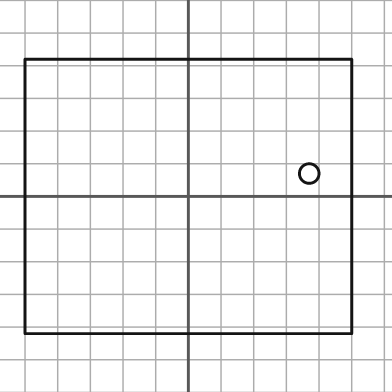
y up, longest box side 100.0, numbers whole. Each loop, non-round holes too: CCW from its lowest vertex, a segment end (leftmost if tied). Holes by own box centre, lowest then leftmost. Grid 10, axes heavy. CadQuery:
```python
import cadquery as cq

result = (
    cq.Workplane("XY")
    .moveTo(-50.0, -42.0)
    .lineTo(50.0, -42.0)
    .lineTo(50.0, 42.0)
    .lineTo(-50.0, 42.0)
    .close()
    .moveTo(37.0, 7.0)
    .circle(3.0)
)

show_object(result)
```